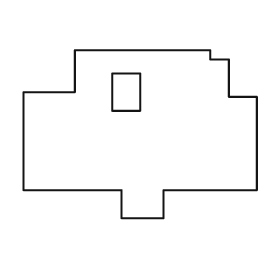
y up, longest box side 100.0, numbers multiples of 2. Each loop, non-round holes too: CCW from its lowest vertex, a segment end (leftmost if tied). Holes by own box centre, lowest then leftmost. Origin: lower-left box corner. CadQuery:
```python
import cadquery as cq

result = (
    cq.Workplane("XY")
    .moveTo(42.0, 0.0)
    .lineTo(60.0, 0.0)
    .lineTo(60.0, 12.0)
    .lineTo(100.0, 12.0)
    .lineTo(100.0, 52.0)
    .lineTo(88.0, 52.0)
    .lineTo(88.0, 68.0)
    .lineTo(80.0, 68.0)
    .lineTo(80.0, 72.0)
    .lineTo(22.0, 72.0)
    .lineTo(22.0, 54.0)
    .lineTo(0.0, 54.0)
    .lineTo(0.0, 12.0)
    .lineTo(42.0, 12.0)
    .close()
    .moveTo(38.0, 46.0)
    .lineTo(50.0, 46.0)
    .lineTo(50.0, 62.0)
    .lineTo(38.0, 62.0)
    .close()
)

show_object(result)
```